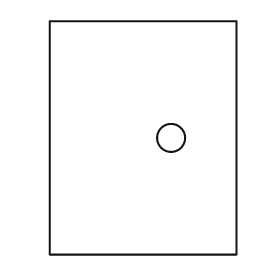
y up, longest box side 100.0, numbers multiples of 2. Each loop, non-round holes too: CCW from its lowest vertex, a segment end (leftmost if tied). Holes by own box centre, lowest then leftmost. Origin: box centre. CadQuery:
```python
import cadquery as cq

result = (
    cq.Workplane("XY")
    .moveTo(-40.0, -50.0)
    .lineTo(40.0, -50.0)
    .lineTo(40.0, 50.0)
    .lineTo(-40.0, 50.0)
    .close()
    .moveTo(12.0, 0.0)
    .circle(6.0)
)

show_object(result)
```